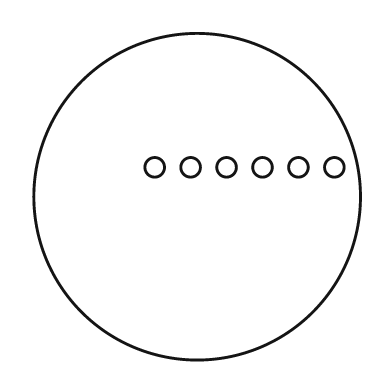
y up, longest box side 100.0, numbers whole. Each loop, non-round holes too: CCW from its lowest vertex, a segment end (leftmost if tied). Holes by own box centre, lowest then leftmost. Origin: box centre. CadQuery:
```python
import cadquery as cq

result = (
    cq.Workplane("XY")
    .moveTo(0.0, 0.0)
    .circle(50.0)
    .moveTo(-13.0, 9.0)
    .circle(3.0)
    .moveTo(-2.0, 9.0)
    .circle(3.0)
    .moveTo(9.0, 9.0)
    .circle(3.0)
    .moveTo(20.0, 9.0)
    .circle(3.0)
    .moveTo(31.0, 9.0)
    .circle(3.0)
    .moveTo(42.0, 9.0)
    .circle(3.0)
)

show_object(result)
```